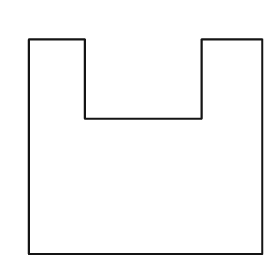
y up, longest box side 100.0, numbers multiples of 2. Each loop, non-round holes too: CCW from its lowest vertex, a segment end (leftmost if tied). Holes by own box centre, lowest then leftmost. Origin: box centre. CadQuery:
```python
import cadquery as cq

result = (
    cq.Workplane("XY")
    .moveTo(-50.0, -46.0)
    .lineTo(50.0, -46.0)
    .lineTo(50.0, 46.0)
    .lineTo(24.0, 46.0)
    .lineTo(24.0, 12.0)
    .lineTo(-26.0, 12.0)
    .lineTo(-26.0, 46.0)
    .lineTo(-50.0, 46.0)
    .close()
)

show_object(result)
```